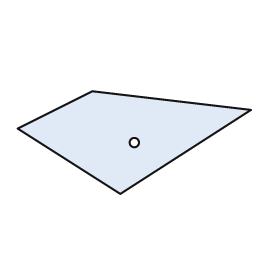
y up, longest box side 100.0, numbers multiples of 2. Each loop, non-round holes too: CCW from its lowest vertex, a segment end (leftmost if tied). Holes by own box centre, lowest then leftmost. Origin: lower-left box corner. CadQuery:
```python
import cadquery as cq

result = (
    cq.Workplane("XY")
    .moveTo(44.0, 0.0)
    .lineTo(100.0, 36.0)
    .lineTo(32.0, 44.0)
    .lineTo(0.0, 28.0)
    .close()
    .moveTo(50.0, 22.0)
    .circle(2.0)
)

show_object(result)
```